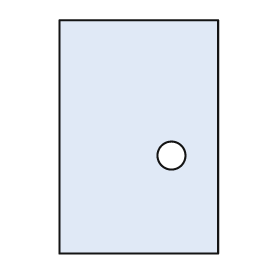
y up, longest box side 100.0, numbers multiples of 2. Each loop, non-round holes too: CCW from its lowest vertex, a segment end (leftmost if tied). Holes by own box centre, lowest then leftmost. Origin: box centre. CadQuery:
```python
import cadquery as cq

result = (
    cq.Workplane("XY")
    .moveTo(-34.0, -50.0)
    .lineTo(34.0, -50.0)
    .lineTo(34.0, 50.0)
    .lineTo(-34.0, 50.0)
    .close()
    .moveTo(14.0, -8.0)
    .circle(6.0)
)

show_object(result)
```